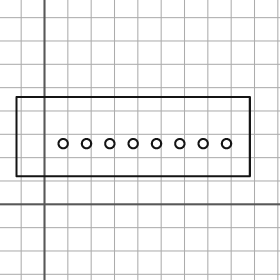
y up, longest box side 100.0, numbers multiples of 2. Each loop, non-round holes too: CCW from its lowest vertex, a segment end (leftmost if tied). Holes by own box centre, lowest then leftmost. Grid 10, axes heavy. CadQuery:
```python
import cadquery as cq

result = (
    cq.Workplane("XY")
    .moveTo(-12.0, 12.0)
    .lineTo(88.0, 12.0)
    .lineTo(88.0, 46.0)
    .lineTo(-12.0, 46.0)
    .close()
    .moveTo(8.0, 26.0)
    .circle(2.0)
    .moveTo(18.0, 26.0)
    .circle(2.0)
    .moveTo(28.0, 26.0)
    .circle(2.0)
    .moveTo(38.0, 26.0)
    .circle(2.0)
    .moveTo(48.0, 26.0)
    .circle(2.0)
    .moveTo(58.0, 26.0)
    .circle(2.0)
    .moveTo(68.0, 26.0)
    .circle(2.0)
    .moveTo(78.0, 26.0)
    .circle(2.0)
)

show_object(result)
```